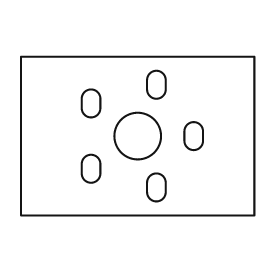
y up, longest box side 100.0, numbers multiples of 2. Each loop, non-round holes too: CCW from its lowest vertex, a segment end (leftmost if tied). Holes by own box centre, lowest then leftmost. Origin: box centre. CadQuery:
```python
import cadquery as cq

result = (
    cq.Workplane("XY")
    .moveTo(-50.0, -34.0)
    .lineTo(50.0, -34.0)
    .lineTo(50.0, 34.0)
    .lineTo(-50.0, 34.0)
    .close()
    .moveTo(4.0, -24.0)
    .threePointArc((8.0, -28.0), (12.0, -24.0))
    .lineTo(12.0, -20.0)
    .threePointArc((8.0, -16.0), (4.0, -20.0))
    .close()
    .moveTo(-24.0, -16.0)
    .threePointArc((-20.0, -20.0), (-16.0, -16.0))
    .lineTo(-16.0, -12.0)
    .threePointArc((-20.0, -8.0), (-24.0, -12.0))
    .close()
    .moveTo(0.0, 0.0)
    .circle(10.0)
    .moveTo(20.0, -2.0)
    .threePointArc((24.0, -6.0), (28.0, -2.0))
    .lineTo(28.0, 2.0)
    .threePointArc((24.0, 6.0), (20.0, 2.0))
    .close()
    .moveTo(-24.0, 12.0)
    .threePointArc((-20.0, 8.0), (-16.0, 12.0))
    .lineTo(-16.0, 16.0)
    .threePointArc((-20.0, 20.0), (-24.0, 16.0))
    .close()
    .moveTo(4.0, 20.0)
    .threePointArc((8.0, 16.0), (12.0, 20.0))
    .lineTo(12.0, 24.0)
    .threePointArc((8.0, 28.0), (4.0, 24.0))
    .close()
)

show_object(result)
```